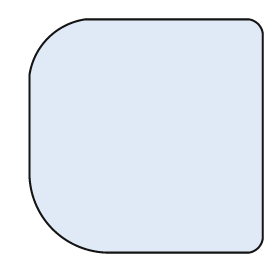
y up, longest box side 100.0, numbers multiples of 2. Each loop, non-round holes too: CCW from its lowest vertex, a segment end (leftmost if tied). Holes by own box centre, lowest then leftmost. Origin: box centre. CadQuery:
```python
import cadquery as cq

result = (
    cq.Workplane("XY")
    .moveTo(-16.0, -50.0)
    .lineTo(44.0, -50.0)
    .threePointArc((48.0, -48.0), (50.0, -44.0))
    .lineTo(50.0, 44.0)
    .threePointArc((48.0, 48.0), (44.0, 50.0))
    .lineTo(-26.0, 50.0)
    .threePointArc((-42.0, 42.0), (-50.0, 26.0))
    .lineTo(-50.0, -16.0)
    .threePointArc((-40.0, -40.0), (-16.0, -50.0))
    .close()
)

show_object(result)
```